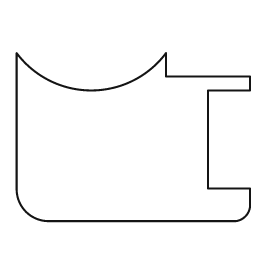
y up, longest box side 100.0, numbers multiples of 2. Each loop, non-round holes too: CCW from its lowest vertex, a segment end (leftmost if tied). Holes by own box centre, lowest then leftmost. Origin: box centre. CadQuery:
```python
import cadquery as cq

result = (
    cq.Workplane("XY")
    .moveTo(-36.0, -36.0)
    .lineTo(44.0, -36.0)
    .threePointArc((48.0, -34.0), (50.0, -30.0))
    .lineTo(50.0, -22.0)
    .lineTo(32.0, -22.0)
    .lineTo(32.0, 20.0)
    .lineTo(50.0, 20.0)
    .lineTo(50.0, 26.0)
    .lineTo(14.0, 26.0)
    .lineTo(14.0, 36.0)
    .threePointArc((-18.0, 20.0), (-50.0, 36.0))
    .lineTo(-50.0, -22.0)
    .threePointArc((-46.0, -32.0), (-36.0, -36.0))
    .close()
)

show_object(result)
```